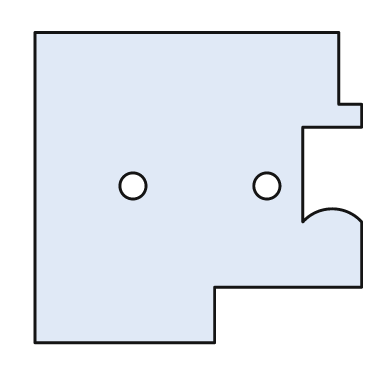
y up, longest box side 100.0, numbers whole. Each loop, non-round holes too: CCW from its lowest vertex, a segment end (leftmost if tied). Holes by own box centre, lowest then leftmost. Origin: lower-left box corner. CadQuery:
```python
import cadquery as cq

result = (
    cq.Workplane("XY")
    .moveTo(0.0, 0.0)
    .lineTo(55.0, 0.0)
    .lineTo(55.0, 17.0)
    .lineTo(100.0, 17.0)
    .lineTo(100.0, 37.0)
    .threePointArc((91.0, 41.0), (82.0, 37.0))
    .lineTo(82.0, 66.0)
    .lineTo(100.0, 66.0)
    .lineTo(100.0, 73.0)
    .lineTo(93.0, 73.0)
    .lineTo(93.0, 95.0)
    .lineTo(0.0, 95.0)
    .close()
    .moveTo(30.0, 48.0)
    .circle(4.0)
    .moveTo(71.0, 48.0)
    .circle(4.0)
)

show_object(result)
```